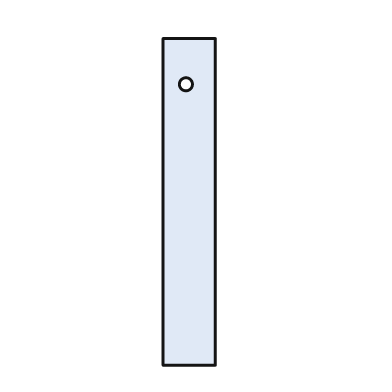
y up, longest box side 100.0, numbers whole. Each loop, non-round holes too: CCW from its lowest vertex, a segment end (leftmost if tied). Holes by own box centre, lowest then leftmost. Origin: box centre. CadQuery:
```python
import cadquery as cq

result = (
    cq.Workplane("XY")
    .moveTo(-8.0, -50.0)
    .lineTo(8.0, -50.0)
    .lineTo(8.0, 50.0)
    .lineTo(-8.0, 50.0)
    .close()
    .moveTo(-1.0, 36.0)
    .circle(2.0)
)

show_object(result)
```